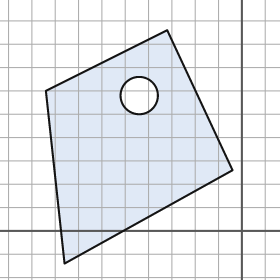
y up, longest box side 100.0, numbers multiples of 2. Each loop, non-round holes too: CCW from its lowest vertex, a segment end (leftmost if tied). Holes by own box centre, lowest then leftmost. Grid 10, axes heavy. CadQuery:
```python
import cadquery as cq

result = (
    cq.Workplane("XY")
    .moveTo(-76.0, -14.0)
    .lineTo(-4.0, 26.0)
    .lineTo(-32.0, 86.0)
    .lineTo(-84.0, 60.0)
    .close()
    .moveTo(-44.0, 58.0)
    .circle(8.0)
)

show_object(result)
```